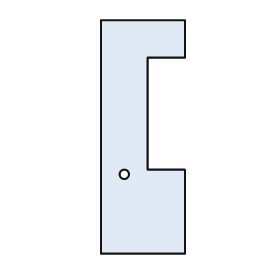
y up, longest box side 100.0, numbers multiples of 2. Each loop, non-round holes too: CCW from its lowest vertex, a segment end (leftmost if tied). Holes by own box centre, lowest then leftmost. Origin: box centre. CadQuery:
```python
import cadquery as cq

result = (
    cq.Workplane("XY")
    .moveTo(-18.0, -50.0)
    .lineTo(18.0, -50.0)
    .lineTo(18.0, -14.0)
    .lineTo(2.0, -14.0)
    .lineTo(2.0, 34.0)
    .lineTo(18.0, 34.0)
    .lineTo(18.0, 50.0)
    .lineTo(-18.0, 50.0)
    .close()
    .moveTo(-8.0, -16.0)
    .circle(2.0)
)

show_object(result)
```